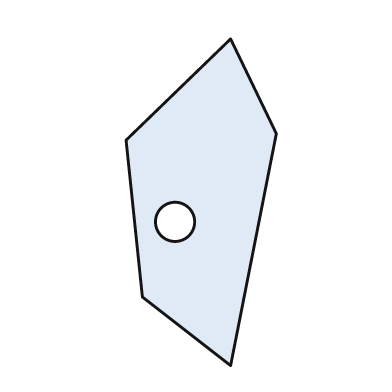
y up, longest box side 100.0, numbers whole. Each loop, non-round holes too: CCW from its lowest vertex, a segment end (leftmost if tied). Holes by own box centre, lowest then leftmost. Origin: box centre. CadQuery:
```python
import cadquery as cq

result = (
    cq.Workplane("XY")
    .moveTo(9.0, -50.0)
    .lineTo(23.0, 21.0)
    .lineTo(9.0, 50.0)
    .lineTo(-23.0, 19.0)
    .lineTo(-18.0, -29.0)
    .close()
    .moveTo(-8.0, -6.0)
    .circle(6.0)
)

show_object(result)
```